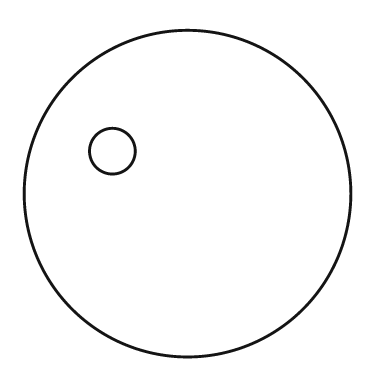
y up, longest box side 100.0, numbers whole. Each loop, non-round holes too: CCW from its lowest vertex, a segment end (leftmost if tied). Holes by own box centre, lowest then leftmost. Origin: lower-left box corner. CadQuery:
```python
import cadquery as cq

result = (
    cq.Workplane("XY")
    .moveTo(50.0, 50.0)
    .circle(50.0)
    .moveTo(27.0, 63.0)
    .circle(7.0)
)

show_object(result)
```